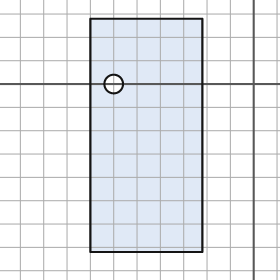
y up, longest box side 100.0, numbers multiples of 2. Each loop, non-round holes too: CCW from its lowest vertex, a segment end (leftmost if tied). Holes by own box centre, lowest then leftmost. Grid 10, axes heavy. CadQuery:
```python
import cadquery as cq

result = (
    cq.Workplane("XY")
    .moveTo(-70.0, -72.0)
    .lineTo(-22.0, -72.0)
    .lineTo(-22.0, 28.0)
    .lineTo(-70.0, 28.0)
    .close()
    .moveTo(-60.0, 0.0)
    .circle(4.0)
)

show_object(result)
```